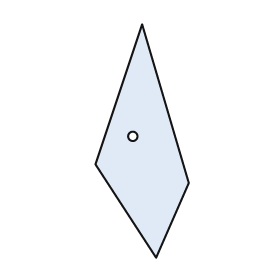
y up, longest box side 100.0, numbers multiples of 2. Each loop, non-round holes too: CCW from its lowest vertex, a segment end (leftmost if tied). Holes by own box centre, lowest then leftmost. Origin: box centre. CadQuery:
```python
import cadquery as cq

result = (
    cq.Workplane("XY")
    .moveTo(6.0, -50.0)
    .lineTo(20.0, -18.0)
    .lineTo(0.0, 50.0)
    .lineTo(-20.0, -10.0)
    .close()
    .moveTo(-4.0, 2.0)
    .circle(2.0)
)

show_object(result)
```